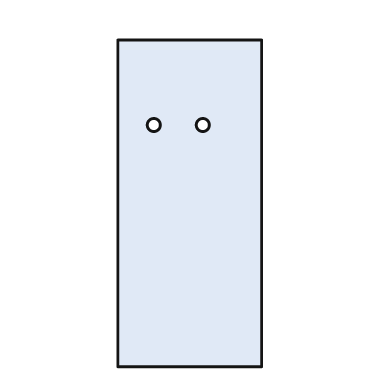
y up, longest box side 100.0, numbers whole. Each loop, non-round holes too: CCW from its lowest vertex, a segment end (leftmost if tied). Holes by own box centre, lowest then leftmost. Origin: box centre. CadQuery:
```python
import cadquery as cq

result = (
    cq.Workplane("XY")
    .moveTo(-22.0, -50.0)
    .lineTo(22.0, -50.0)
    .lineTo(22.0, 50.0)
    .lineTo(-22.0, 50.0)
    .close()
    .moveTo(-11.0, 24.0)
    .circle(2.0)
    .moveTo(4.0, 24.0)
    .circle(2.0)
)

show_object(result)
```